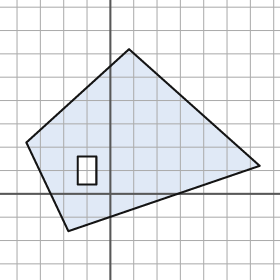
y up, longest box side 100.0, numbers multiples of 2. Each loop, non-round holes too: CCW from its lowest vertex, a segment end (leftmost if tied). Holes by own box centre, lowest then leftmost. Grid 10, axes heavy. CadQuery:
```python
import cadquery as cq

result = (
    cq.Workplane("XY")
    .moveTo(-18.0, -16.0)
    .lineTo(64.0, 12.0)
    .lineTo(8.0, 62.0)
    .lineTo(-36.0, 22.0)
    .close()
    .moveTo(-14.0, 4.0)
    .lineTo(-6.0, 4.0)
    .lineTo(-6.0, 16.0)
    .lineTo(-14.0, 16.0)
    .close()
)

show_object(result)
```